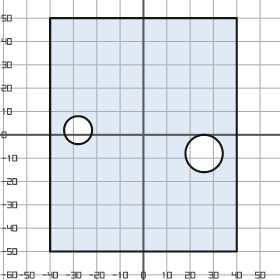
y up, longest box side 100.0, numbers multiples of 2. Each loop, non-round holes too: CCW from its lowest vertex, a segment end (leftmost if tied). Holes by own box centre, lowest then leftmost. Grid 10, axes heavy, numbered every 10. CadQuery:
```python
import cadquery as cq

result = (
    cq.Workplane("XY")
    .moveTo(-40.0, -50.0)
    .lineTo(40.0, -50.0)
    .lineTo(40.0, 50.0)
    .lineTo(-40.0, 50.0)
    .close()
    .moveTo(26.0, -8.0)
    .circle(8.0)
    .moveTo(-28.0, 2.0)
    .circle(6.0)
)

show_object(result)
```